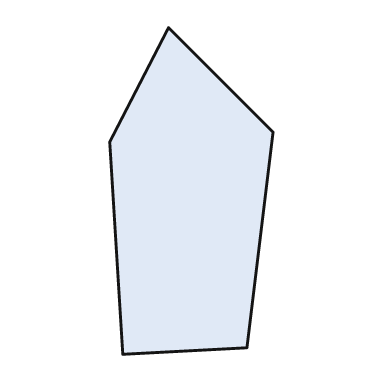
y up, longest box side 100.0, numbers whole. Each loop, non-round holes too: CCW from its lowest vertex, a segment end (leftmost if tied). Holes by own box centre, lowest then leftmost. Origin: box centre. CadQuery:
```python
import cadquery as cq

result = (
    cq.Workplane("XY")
    .moveTo(-21.0, -50.0)
    .lineTo(17.0, -48.0)
    .lineTo(25.0, 18.0)
    .lineTo(-7.0, 50.0)
    .lineTo(-25.0, 15.0)
    .close()
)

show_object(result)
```